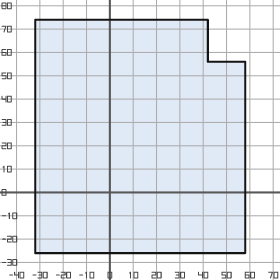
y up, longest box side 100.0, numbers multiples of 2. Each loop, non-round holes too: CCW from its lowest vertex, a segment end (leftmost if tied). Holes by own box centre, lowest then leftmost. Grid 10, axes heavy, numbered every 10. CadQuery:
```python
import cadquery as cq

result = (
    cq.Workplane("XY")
    .moveTo(-32.0, -26.0)
    .lineTo(58.0, -26.0)
    .lineTo(58.0, 56.0)
    .lineTo(42.0, 56.0)
    .lineTo(42.0, 74.0)
    .lineTo(-32.0, 74.0)
    .close()
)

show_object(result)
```